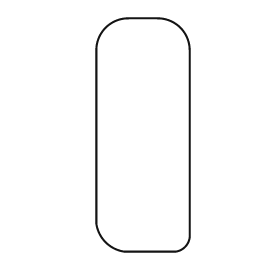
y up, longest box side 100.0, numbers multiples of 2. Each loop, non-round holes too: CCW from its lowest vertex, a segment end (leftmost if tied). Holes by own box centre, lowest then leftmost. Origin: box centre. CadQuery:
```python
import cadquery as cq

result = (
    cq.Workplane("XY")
    .moveTo(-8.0, -50.0)
    .lineTo(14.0, -50.0)
    .threePointArc((18.0, -48.0), (20.0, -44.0))
    .lineTo(20.0, 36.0)
    .threePointArc((16.0, 46.0), (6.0, 50.0))
    .lineTo(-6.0, 50.0)
    .threePointArc((-16.0, 46.0), (-20.0, 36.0))
    .lineTo(-20.0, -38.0)
    .threePointArc((-16.0, -46.0), (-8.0, -50.0))
    .close()
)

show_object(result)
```